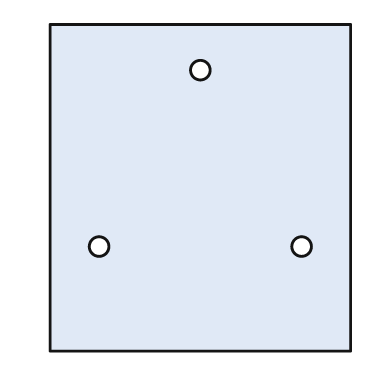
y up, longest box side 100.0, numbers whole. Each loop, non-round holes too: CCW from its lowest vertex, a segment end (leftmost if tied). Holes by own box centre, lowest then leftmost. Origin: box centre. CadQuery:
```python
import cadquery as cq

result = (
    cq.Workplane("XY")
    .moveTo(-46.0, -50.0)
    .lineTo(46.0, -50.0)
    .lineTo(46.0, 50.0)
    .lineTo(-46.0, 50.0)
    .close()
    .moveTo(-31.0, -18.0)
    .circle(3.0)
    .moveTo(31.0, -18.0)
    .circle(3.0)
    .moveTo(0.0, 36.0)
    .circle(3.0)
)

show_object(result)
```